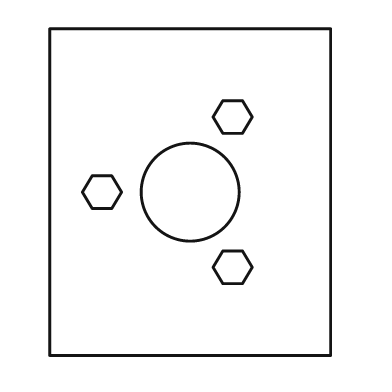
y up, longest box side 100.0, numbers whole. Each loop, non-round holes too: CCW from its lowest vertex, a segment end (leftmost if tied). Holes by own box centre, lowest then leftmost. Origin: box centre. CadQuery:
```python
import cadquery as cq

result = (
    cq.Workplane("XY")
    .moveTo(-43.0, -50.0)
    .lineTo(43.0, -50.0)
    .lineTo(43.0, 50.0)
    .lineTo(-43.0, 50.0)
    .close()
    .moveTo(10.0, -28.0)
    .lineTo(16.0, -28.0)
    .lineTo(19.0, -23.0)
    .lineTo(16.0, -18.0)
    .lineTo(10.0, -18.0)
    .lineTo(7.0, -23.0)
    .close()
    .moveTo(-30.0, -5.0)
    .lineTo(-24.0, -5.0)
    .lineTo(-21.0, 0.0)
    .lineTo(-24.0, 5.0)
    .lineTo(-30.0, 5.0)
    .lineTo(-33.0, 0.0)
    .close()
    .moveTo(0.0, 0.0)
    .circle(15.0)
    .moveTo(10.0, 18.0)
    .lineTo(16.0, 18.0)
    .lineTo(19.0, 23.0)
    .lineTo(16.0, 28.0)
    .lineTo(10.0, 28.0)
    .lineTo(7.0, 23.0)
    .close()
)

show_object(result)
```